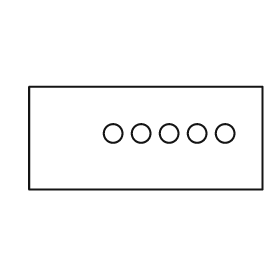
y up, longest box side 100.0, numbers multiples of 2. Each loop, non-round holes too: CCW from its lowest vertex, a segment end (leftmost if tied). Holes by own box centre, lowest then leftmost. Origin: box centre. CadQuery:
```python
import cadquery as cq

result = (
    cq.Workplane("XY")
    .moveTo(-50.0, -22.0)
    .lineTo(50.0, -22.0)
    .lineTo(50.0, 22.0)
    .lineTo(-50.0, 22.0)
    .close()
    .moveTo(-14.0, 2.0)
    .circle(4.0)
    .moveTo(-2.0, 2.0)
    .circle(4.0)
    .moveTo(10.0, 2.0)
    .circle(4.0)
    .moveTo(22.0, 2.0)
    .circle(4.0)
    .moveTo(34.0, 2.0)
    .circle(4.0)
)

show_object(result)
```